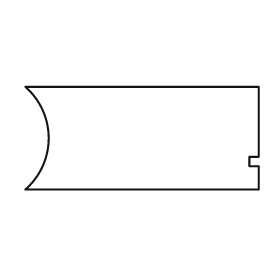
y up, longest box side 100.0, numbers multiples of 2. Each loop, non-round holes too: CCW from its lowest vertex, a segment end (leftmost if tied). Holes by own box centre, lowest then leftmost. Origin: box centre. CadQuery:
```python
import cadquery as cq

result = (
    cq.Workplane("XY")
    .moveTo(-50.0, -22.0)
    .lineTo(50.0, -22.0)
    .lineTo(50.0, -12.0)
    .lineTo(46.0, -12.0)
    .lineTo(46.0, -8.0)
    .lineTo(50.0, -8.0)
    .lineTo(50.0, 22.0)
    .lineTo(-50.0, 22.0)
    .threePointArc((-40.0, 0.0), (-50.0, -22.0))
    .close()
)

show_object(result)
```